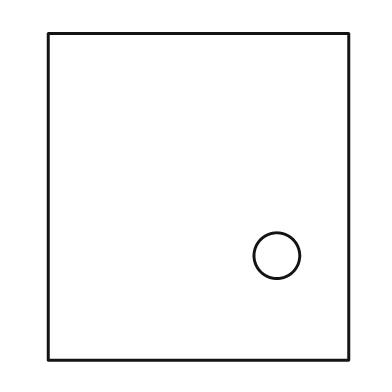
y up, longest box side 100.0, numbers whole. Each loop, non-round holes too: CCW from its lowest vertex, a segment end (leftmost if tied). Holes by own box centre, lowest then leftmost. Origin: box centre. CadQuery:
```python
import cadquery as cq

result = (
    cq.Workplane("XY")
    .moveTo(-46.0, -50.0)
    .lineTo(46.0, -50.0)
    .lineTo(46.0, 50.0)
    .lineTo(-46.0, 50.0)
    .close()
    .moveTo(24.0, -18.0)
    .circle(7.0)
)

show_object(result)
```